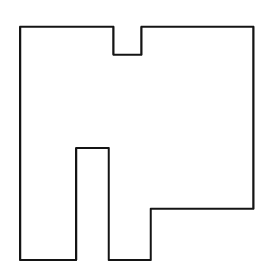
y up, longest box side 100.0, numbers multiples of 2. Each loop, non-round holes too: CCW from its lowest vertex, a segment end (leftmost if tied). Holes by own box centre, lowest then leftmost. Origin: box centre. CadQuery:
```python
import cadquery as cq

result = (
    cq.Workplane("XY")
    .moveTo(-50.0, -50.0)
    .lineTo(-26.0, -50.0)
    .lineTo(-26.0, -2.0)
    .lineTo(-12.0, -2.0)
    .lineTo(-12.0, -50.0)
    .lineTo(6.0, -50.0)
    .lineTo(6.0, -28.0)
    .lineTo(50.0, -28.0)
    .lineTo(50.0, 50.0)
    .lineTo(2.0, 50.0)
    .lineTo(2.0, 38.0)
    .lineTo(-10.0, 38.0)
    .lineTo(-10.0, 50.0)
    .lineTo(-50.0, 50.0)
    .close()
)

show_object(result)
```